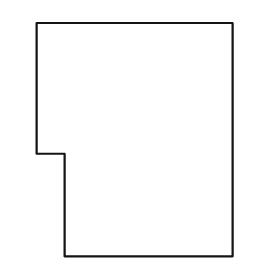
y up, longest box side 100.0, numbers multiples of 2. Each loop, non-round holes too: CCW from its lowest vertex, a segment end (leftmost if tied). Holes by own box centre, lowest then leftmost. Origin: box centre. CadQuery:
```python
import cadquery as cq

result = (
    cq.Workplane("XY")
    .moveTo(-30.0, -50.0)
    .lineTo(42.0, -50.0)
    .lineTo(42.0, 50.0)
    .lineTo(-42.0, 50.0)
    .lineTo(-42.0, -6.0)
    .lineTo(-30.0, -6.0)
    .close()
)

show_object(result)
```